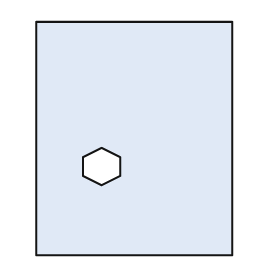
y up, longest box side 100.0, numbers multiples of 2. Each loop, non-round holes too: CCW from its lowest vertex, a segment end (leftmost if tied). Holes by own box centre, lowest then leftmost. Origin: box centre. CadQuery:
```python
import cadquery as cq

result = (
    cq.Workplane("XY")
    .moveTo(-42.0, -50.0)
    .lineTo(42.0, -50.0)
    .lineTo(42.0, 50.0)
    .lineTo(-42.0, 50.0)
    .close()
    .moveTo(-14.0, -20.0)
    .lineTo(-6.0, -16.0)
    .lineTo(-6.0, -8.0)
    .lineTo(-14.0, -4.0)
    .lineTo(-22.0, -8.0)
    .lineTo(-22.0, -16.0)
    .close()
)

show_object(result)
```